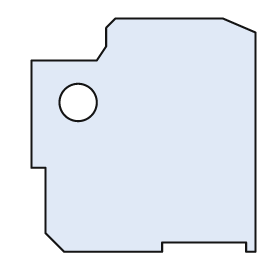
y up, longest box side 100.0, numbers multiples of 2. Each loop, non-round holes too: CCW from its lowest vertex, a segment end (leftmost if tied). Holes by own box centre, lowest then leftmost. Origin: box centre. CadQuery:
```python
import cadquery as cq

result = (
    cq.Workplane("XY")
    .moveTo(-34.0, -50.0)
    .lineTo(8.0, -50.0)
    .lineTo(8.0, -46.0)
    .lineTo(44.0, -46.0)
    .lineTo(44.0, -50.0)
    .lineTo(48.0, -50.0)
    .lineTo(48.0, 44.0)
    .lineTo(34.0, 50.0)
    .lineTo(-12.0, 50.0)
    .lineTo(-16.0, 46.0)
    .lineTo(-16.0, 38.0)
    .lineTo(-20.0, 32.0)
    .lineTo(-48.0, 32.0)
    .lineTo(-48.0, -14.0)
    .lineTo(-42.0, -14.0)
    .lineTo(-42.0, -42.0)
    .close()
    .moveTo(-28.0, 14.0)
    .circle(8.0)
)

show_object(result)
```